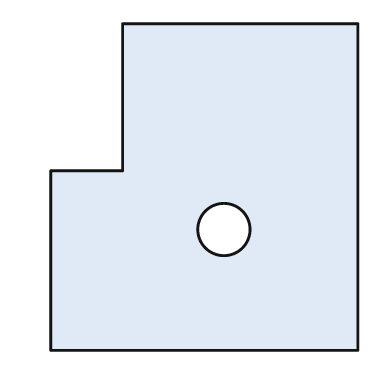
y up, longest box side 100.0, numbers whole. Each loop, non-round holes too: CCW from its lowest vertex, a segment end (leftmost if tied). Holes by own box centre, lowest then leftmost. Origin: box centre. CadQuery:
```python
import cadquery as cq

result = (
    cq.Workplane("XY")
    .moveTo(-47.0, -50.0)
    .lineTo(47.0, -50.0)
    .lineTo(47.0, 50.0)
    .lineTo(-25.0, 50.0)
    .lineTo(-25.0, 5.0)
    .lineTo(-47.0, 5.0)
    .close()
    .moveTo(6.0, -13.0)
    .circle(8.0)
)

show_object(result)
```